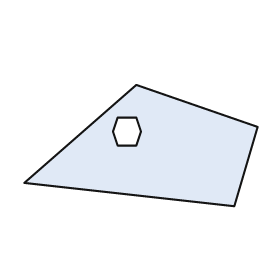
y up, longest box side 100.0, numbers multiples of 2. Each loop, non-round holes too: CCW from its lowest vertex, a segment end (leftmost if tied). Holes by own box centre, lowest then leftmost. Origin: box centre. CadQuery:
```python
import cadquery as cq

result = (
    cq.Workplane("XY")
    .moveTo(40.0, -26.0)
    .lineTo(50.0, 8.0)
    .lineTo(-2.0, 26.0)
    .lineTo(-50.0, -16.0)
    .close()
    .moveTo(-10.0, 0.0)
    .lineTo(-2.0, 0.0)
    .lineTo(0.0, 6.0)
    .lineTo(-2.0, 12.0)
    .lineTo(-10.0, 12.0)
    .lineTo(-12.0, 6.0)
    .close()
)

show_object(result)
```